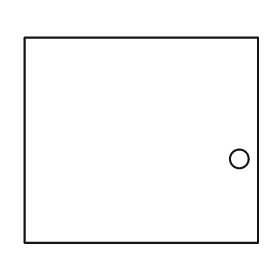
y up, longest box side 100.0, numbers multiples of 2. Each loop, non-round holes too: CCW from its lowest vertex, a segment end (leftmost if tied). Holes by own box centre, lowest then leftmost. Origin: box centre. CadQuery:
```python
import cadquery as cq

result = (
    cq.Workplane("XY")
    .moveTo(-50.0, -44.0)
    .lineTo(50.0, -44.0)
    .lineTo(50.0, 44.0)
    .lineTo(-50.0, 44.0)
    .close()
    .moveTo(42.0, -8.0)
    .circle(4.0)
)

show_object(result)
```